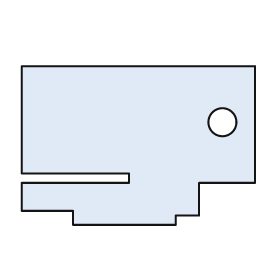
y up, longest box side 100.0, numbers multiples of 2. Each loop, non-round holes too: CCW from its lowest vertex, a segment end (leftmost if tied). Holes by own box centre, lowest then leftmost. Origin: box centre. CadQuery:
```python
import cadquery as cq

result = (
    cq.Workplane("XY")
    .moveTo(-28.0, -34.0)
    .lineTo(16.0, -34.0)
    .lineTo(16.0, -30.0)
    .lineTo(26.0, -30.0)
    .lineTo(26.0, -16.0)
    .lineTo(50.0, -16.0)
    .lineTo(50.0, 34.0)
    .lineTo(-50.0, 34.0)
    .lineTo(-50.0, -12.0)
    .lineTo(-4.0, -12.0)
    .lineTo(-4.0, -16.0)
    .lineTo(-50.0, -16.0)
    .lineTo(-50.0, -28.0)
    .lineTo(-28.0, -28.0)
    .close()
    .moveTo(36.0, 10.0)
    .circle(6.0)
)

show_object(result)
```